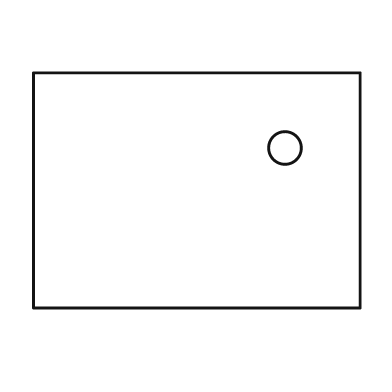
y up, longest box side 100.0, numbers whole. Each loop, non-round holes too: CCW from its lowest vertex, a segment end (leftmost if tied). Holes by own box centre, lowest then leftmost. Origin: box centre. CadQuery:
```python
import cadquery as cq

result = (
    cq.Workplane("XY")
    .moveTo(-50.0, -36.0)
    .lineTo(50.0, -36.0)
    .lineTo(50.0, 36.0)
    .lineTo(-50.0, 36.0)
    .close()
    .moveTo(27.0, 13.0)
    .circle(5.0)
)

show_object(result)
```